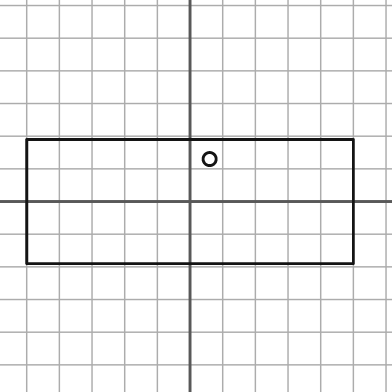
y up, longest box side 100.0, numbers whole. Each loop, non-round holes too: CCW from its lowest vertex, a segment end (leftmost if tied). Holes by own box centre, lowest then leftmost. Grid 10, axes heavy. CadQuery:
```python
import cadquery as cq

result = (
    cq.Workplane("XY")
    .moveTo(-50.0, -19.0)
    .lineTo(50.0, -19.0)
    .lineTo(50.0, 19.0)
    .lineTo(-50.0, 19.0)
    .close()
    .moveTo(6.0, 13.0)
    .circle(2.0)
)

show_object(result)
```